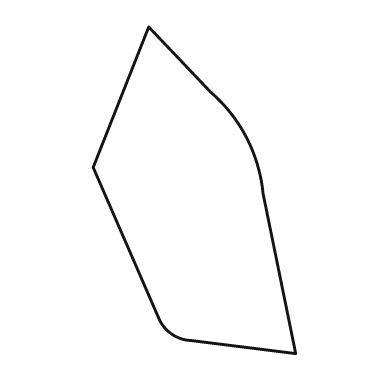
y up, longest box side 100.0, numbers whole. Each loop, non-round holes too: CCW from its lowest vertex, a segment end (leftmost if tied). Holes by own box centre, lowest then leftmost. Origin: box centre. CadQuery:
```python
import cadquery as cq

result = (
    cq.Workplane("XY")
    .moveTo(31.0, -50.0)
    .lineTo(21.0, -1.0)
    .threePointArc((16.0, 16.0), (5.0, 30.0))
    .lineTo(-14.0, 50.0)
    .lineTo(-31.0, 7.0)
    .lineTo(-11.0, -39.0)
    .threePointArc((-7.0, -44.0), (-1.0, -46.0))
    .close()
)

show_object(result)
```